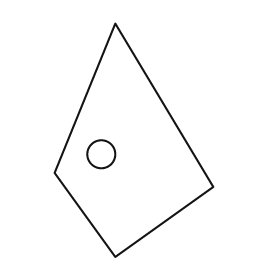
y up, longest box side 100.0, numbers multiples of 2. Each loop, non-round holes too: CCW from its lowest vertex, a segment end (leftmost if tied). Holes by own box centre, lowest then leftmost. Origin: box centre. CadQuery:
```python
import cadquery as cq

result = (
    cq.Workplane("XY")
    .moveTo(-8.0, -50.0)
    .lineTo(34.0, -20.0)
    .lineTo(-8.0, 50.0)
    .lineTo(-34.0, -14.0)
    .close()
    .moveTo(-14.0, -6.0)
    .circle(6.0)
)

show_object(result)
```